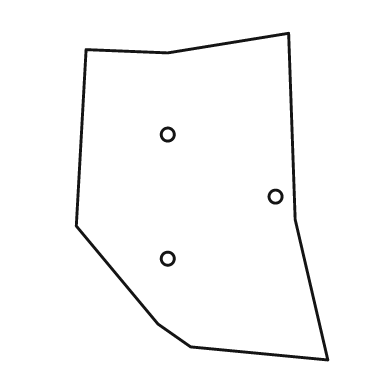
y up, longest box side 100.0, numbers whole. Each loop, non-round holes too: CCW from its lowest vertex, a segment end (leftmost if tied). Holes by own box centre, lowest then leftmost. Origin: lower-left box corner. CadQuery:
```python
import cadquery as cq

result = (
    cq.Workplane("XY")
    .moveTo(77.0, 0.0)
    .lineTo(67.0, 43.0)
    .lineTo(65.0, 100.0)
    .lineTo(28.0, 94.0)
    .lineTo(3.0, 95.0)
    .lineTo(0.0, 41.0)
    .lineTo(25.0, 11.0)
    .lineTo(35.0, 4.0)
    .close()
    .moveTo(28.0, 31.0)
    .circle(2.0)
    .moveTo(61.0, 50.0)
    .circle(2.0)
    .moveTo(28.0, 69.0)
    .circle(2.0)
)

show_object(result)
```